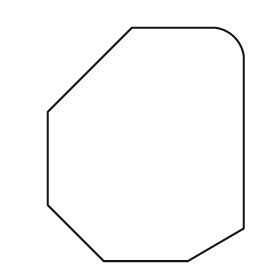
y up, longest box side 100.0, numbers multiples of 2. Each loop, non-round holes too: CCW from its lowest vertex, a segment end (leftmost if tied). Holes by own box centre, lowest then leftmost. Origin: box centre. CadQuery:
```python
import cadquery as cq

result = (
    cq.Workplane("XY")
    .moveTo(-18.0, -50.0)
    .lineTo(18.0, -50.0)
    .lineTo(42.0, -36.0)
    .lineTo(42.0, 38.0)
    .threePointArc((38.0, 46.0), (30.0, 50.0))
    .lineTo(-6.0, 50.0)
    .lineTo(-42.0, 14.0)
    .lineTo(-42.0, -26.0)
    .close()
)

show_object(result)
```